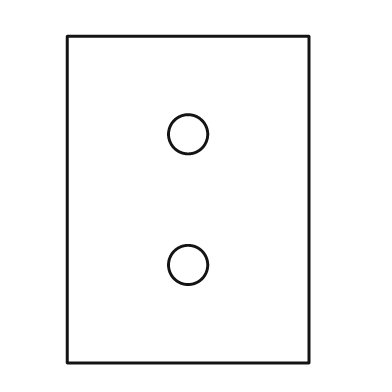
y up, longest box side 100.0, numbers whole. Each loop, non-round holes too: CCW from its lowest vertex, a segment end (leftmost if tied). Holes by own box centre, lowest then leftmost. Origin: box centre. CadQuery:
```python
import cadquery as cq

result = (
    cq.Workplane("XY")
    .moveTo(-37.0, -50.0)
    .lineTo(37.0, -50.0)
    .lineTo(37.0, 50.0)
    .lineTo(-37.0, 50.0)
    .close()
    .moveTo(0.0, -20.0)
    .circle(6.0)
    .moveTo(0.0, 20.0)
    .circle(6.0)
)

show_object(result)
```